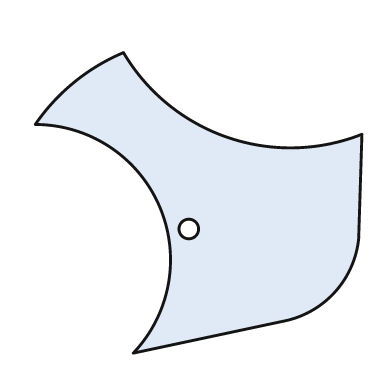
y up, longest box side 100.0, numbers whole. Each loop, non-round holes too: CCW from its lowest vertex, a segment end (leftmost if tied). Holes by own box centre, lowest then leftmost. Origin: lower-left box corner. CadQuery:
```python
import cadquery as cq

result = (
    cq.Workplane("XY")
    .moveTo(30.0, 0.0)
    .lineTo(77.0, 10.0)
    .threePointArc((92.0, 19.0), (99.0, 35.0))
    .lineTo(100.0, 67.0)
    .threePointArc((59.0, 66.0), (27.0, 92.0))
    .threePointArc((12.0, 83.0), (0.0, 70.0))
    .threePointArc((38.0, 45.0), (30.0, 0.0))
    .close()
    .moveTo(47.0, 38.0)
    .circle(3.0)
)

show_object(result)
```